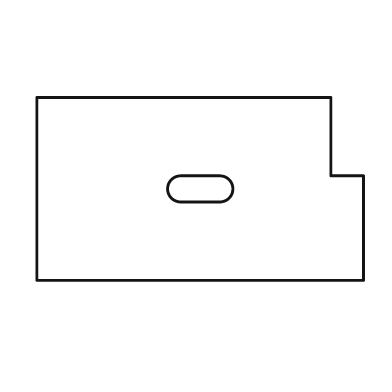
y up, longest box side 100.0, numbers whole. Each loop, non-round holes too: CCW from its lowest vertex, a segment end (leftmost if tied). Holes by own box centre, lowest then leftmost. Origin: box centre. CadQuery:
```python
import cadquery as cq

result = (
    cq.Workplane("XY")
    .moveTo(-50.0, -28.0)
    .lineTo(50.0, -28.0)
    .lineTo(50.0, 4.0)
    .lineTo(40.0, 4.0)
    .lineTo(40.0, 28.0)
    .lineTo(-50.0, 28.0)
    .close()
    .moveTo(-6.0, -4.0)
    .lineTo(6.0, -4.0)
    .threePointArc((10.0, 0.0), (6.0, 4.0))
    .lineTo(-6.0, 4.0)
    .threePointArc((-10.0, 0.0), (-6.0, -4.0))
    .close()
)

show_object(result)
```